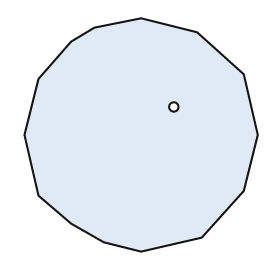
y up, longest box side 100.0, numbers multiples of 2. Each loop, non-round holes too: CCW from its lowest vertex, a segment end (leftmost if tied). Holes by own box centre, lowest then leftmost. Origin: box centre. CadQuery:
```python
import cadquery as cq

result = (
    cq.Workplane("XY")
    .moveTo(0.0, -50.0)
    .lineTo(26.0, -44.0)
    .lineTo(44.0, -24.0)
    .lineTo(50.0, 0.0)
    .lineTo(44.0, 26.0)
    .lineTo(24.0, 44.0)
    .lineTo(0.0, 50.0)
    .lineTo(-20.0, 46.0)
    .lineTo(-30.0, 40.0)
    .lineTo(-44.0, 24.0)
    .lineTo(-50.0, 0.0)
    .lineTo(-44.0, -26.0)
    .lineTo(-30.0, -38.0)
    .lineTo(-16.0, -46.0)
    .close()
    .moveTo(14.0, 12.0)
    .circle(2.0)
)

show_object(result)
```